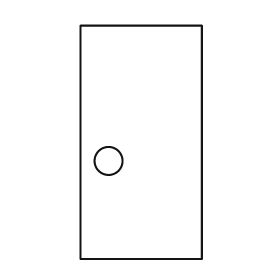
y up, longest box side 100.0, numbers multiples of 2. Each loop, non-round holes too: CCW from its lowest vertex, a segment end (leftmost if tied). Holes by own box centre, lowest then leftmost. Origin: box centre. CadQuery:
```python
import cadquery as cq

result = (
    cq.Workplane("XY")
    .moveTo(-26.0, -50.0)
    .lineTo(26.0, -50.0)
    .lineTo(26.0, 50.0)
    .lineTo(-26.0, 50.0)
    .close()
    .moveTo(-14.0, -8.0)
    .circle(6.0)
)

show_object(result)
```